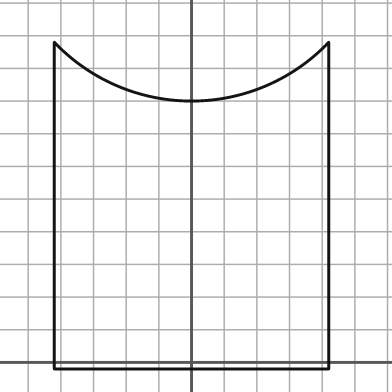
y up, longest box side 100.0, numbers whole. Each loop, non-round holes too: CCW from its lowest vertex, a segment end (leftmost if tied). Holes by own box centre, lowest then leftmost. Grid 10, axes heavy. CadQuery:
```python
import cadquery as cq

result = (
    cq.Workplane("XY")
    .moveTo(-42.0, -2.0)
    .lineTo(42.0, -2.0)
    .lineTo(42.0, 98.0)
    .threePointArc((0.0, 80.0), (-42.0, 98.0))
    .close()
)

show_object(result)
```